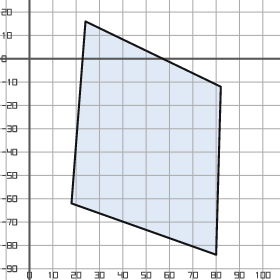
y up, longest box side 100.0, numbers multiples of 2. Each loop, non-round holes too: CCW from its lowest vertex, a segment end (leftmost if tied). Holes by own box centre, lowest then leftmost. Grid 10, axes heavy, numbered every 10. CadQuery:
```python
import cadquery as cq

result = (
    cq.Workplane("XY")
    .moveTo(80.0, -84.0)
    .lineTo(82.0, -12.0)
    .lineTo(24.0, 16.0)
    .lineTo(18.0, -62.0)
    .close()
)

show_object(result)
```